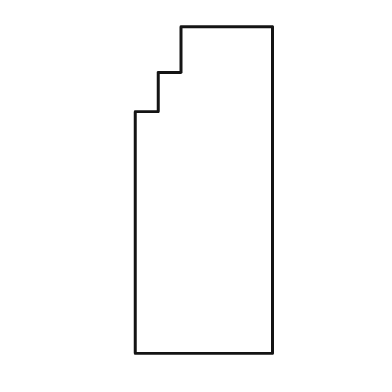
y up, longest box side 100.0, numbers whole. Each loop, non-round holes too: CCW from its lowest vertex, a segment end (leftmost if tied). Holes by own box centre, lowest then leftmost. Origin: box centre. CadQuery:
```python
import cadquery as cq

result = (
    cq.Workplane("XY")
    .moveTo(-21.0, -50.0)
    .lineTo(21.0, -50.0)
    .lineTo(21.0, 50.0)
    .lineTo(-7.0, 50.0)
    .lineTo(-7.0, 36.0)
    .lineTo(-14.0, 36.0)
    .lineTo(-14.0, 24.0)
    .lineTo(-21.0, 24.0)
    .close()
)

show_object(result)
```